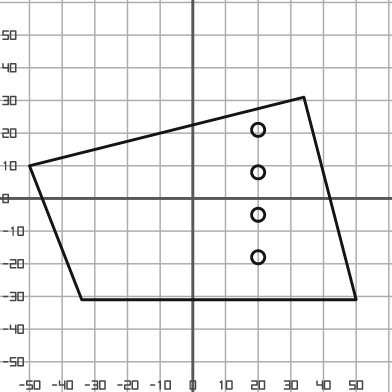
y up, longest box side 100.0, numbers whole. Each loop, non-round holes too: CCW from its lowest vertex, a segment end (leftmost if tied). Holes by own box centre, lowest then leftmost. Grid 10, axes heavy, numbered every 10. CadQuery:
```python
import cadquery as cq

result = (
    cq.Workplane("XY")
    .moveTo(-34.0, -31.0)
    .lineTo(50.0, -31.0)
    .lineTo(34.0, 31.0)
    .lineTo(-50.0, 10.0)
    .close()
    .moveTo(20.0, -18.0)
    .circle(2.0)
    .moveTo(20.0, -5.0)
    .circle(2.0)
    .moveTo(20.0, 8.0)
    .circle(2.0)
    .moveTo(20.0, 21.0)
    .circle(2.0)
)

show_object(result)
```